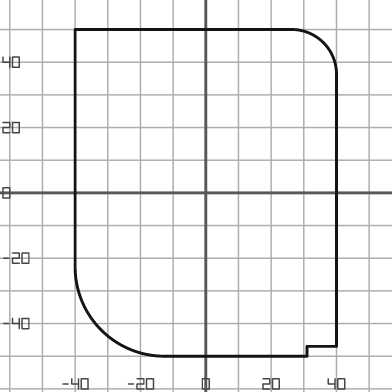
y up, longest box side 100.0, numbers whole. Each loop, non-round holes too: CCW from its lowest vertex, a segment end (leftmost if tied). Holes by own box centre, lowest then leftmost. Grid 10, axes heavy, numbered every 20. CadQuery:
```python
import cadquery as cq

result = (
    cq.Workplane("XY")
    .moveTo(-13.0, -50.0)
    .lineTo(31.0, -50.0)
    .lineTo(31.0, -47.0)
    .lineTo(40.0, -47.0)
    .lineTo(40.0, 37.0)
    .threePointArc((36.0, 46.0), (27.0, 50.0))
    .lineTo(-40.0, 50.0)
    .lineTo(-40.0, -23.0)
    .threePointArc((-32.0, -42.0), (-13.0, -50.0))
    .close()
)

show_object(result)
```